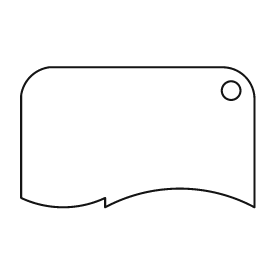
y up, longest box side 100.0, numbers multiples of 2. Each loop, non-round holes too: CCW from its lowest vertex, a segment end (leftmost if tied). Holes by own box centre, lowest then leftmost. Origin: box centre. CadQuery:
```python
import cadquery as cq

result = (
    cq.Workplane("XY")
    .moveTo(-14.0, -30.0)
    .threePointArc((18.0, -22.0), (50.0, -30.0))
    .lineTo(50.0, 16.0)
    .threePointArc((46.0, 26.0), (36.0, 30.0))
    .lineTo(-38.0, 30.0)
    .threePointArc((-46.0, 26.0), (-50.0, 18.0))
    .lineTo(-50.0, -26.0)
    .threePointArc((-32.0, -30.0), (-14.0, -26.0))
    .close()
    .moveTo(40.0, 20.0)
    .circle(4.0)
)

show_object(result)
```